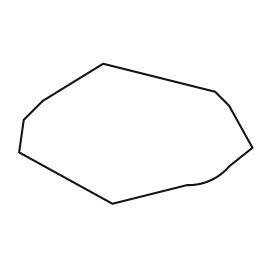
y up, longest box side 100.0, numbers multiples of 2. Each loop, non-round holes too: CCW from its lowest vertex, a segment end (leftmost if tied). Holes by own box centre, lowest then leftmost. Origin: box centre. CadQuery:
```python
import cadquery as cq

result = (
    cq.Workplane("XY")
    .moveTo(-10.0, -30.0)
    .lineTo(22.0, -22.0)
    .threePointArc((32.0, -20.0), (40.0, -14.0))
    .lineTo(50.0, -6.0)
    .lineTo(40.0, 12.0)
    .lineTo(34.0, 18.0)
    .lineTo(-14.0, 30.0)
    .lineTo(-40.0, 14.0)
    .lineTo(-48.0, 6.0)
    .lineTo(-50.0, -8.0)
    .close()
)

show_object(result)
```